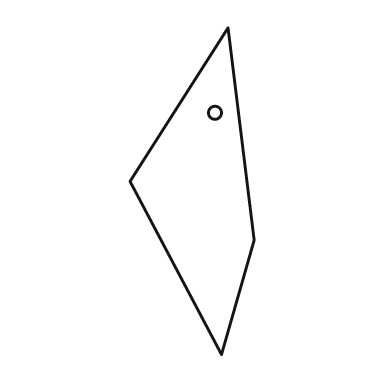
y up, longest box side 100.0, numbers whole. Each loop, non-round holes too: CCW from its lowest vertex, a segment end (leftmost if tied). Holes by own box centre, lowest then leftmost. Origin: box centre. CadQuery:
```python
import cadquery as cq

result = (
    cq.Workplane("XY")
    .moveTo(9.0, -50.0)
    .lineTo(19.0, -15.0)
    .lineTo(11.0, 50.0)
    .lineTo(-19.0, 3.0)
    .close()
    .moveTo(7.0, 24.0)
    .circle(2.0)
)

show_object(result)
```